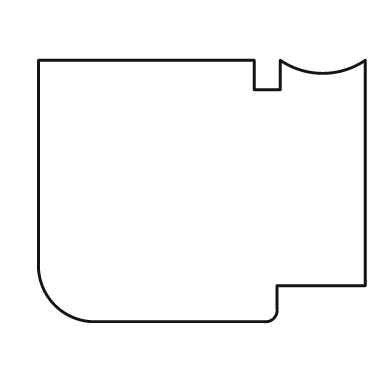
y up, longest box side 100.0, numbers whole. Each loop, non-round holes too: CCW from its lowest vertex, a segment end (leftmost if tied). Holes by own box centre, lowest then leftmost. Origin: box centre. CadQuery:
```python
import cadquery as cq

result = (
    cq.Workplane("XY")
    .moveTo(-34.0, -40.0)
    .lineTo(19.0, -40.0)
    .threePointArc((22.0, -39.0), (23.0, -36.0))
    .lineTo(23.0, -29.0)
    .lineTo(50.0, -29.0)
    .lineTo(50.0, 40.0)
    .threePointArc((37.0, 36.0), (24.0, 40.0))
    .lineTo(24.0, 31.0)
    .lineTo(16.0, 31.0)
    .lineTo(16.0, 40.0)
    .lineTo(-50.0, 40.0)
    .lineTo(-50.0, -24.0)
    .threePointArc((-45.0, -35.0), (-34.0, -40.0))
    .close()
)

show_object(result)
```